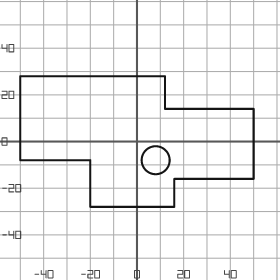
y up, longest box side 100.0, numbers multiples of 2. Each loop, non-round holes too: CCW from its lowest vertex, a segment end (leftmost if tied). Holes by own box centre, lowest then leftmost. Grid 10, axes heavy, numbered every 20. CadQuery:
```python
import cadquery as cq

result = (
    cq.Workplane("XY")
    .moveTo(-20.0, -28.0)
    .lineTo(16.0, -28.0)
    .lineTo(16.0, -16.0)
    .lineTo(50.0, -16.0)
    .lineTo(50.0, 14.0)
    .lineTo(12.0, 14.0)
    .lineTo(12.0, 28.0)
    .lineTo(-50.0, 28.0)
    .lineTo(-50.0, -8.0)
    .lineTo(-20.0, -8.0)
    .close()
    .moveTo(8.0, -8.0)
    .circle(6.0)
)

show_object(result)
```